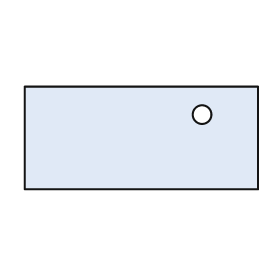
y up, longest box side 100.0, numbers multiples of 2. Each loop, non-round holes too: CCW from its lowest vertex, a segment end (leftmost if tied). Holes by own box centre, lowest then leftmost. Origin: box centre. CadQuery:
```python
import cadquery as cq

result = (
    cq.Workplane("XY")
    .moveTo(-50.0, -22.0)
    .lineTo(50.0, -22.0)
    .lineTo(50.0, 22.0)
    .lineTo(-50.0, 22.0)
    .close()
    .moveTo(26.0, 10.0)
    .circle(4.0)
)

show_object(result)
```